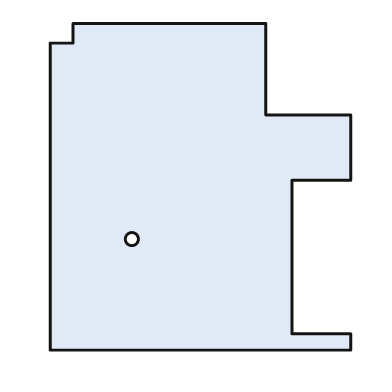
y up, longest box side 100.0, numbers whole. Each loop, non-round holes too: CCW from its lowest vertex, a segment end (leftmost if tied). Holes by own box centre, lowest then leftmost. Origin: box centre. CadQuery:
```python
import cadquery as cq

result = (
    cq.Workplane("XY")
    .moveTo(-46.0, -50.0)
    .lineTo(46.0, -50.0)
    .lineTo(46.0, -45.0)
    .lineTo(28.0, -45.0)
    .lineTo(28.0, 2.0)
    .lineTo(46.0, 2.0)
    .lineTo(46.0, 22.0)
    .lineTo(20.0, 22.0)
    .lineTo(20.0, 50.0)
    .lineTo(-39.0, 50.0)
    .lineTo(-39.0, 44.0)
    .lineTo(-46.0, 44.0)
    .close()
    .moveTo(-21.0, -16.0)
    .circle(2.0)
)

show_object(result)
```